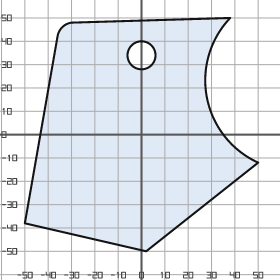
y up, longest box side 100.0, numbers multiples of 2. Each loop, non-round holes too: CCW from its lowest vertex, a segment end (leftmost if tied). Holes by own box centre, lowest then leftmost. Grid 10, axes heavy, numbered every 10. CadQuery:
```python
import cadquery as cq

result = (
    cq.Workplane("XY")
    .moveTo(2.0, -50.0)
    .lineTo(50.0, -12.0)
    .threePointArc((28.0, 16.0), (38.0, 50.0))
    .lineTo(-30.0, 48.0)
    .threePointArc((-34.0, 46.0), (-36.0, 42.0))
    .lineTo(-50.0, -38.0)
    .close()
    .moveTo(0.0, 34.0)
    .circle(6.0)
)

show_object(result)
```